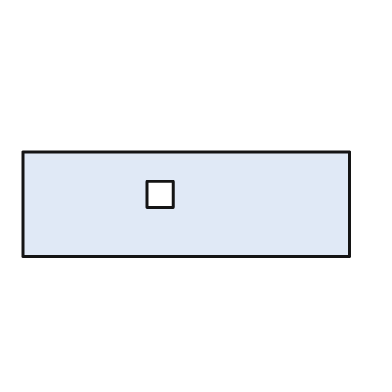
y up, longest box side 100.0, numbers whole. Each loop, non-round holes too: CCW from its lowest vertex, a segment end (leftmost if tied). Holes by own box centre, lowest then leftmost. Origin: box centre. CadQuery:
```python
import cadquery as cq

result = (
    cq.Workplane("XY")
    .moveTo(-50.0, -16.0)
    .lineTo(50.0, -16.0)
    .lineTo(50.0, 16.0)
    .lineTo(-50.0, 16.0)
    .close()
    .moveTo(-12.0, -1.0)
    .lineTo(-4.0, -1.0)
    .lineTo(-4.0, 7.0)
    .lineTo(-12.0, 7.0)
    .close()
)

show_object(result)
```